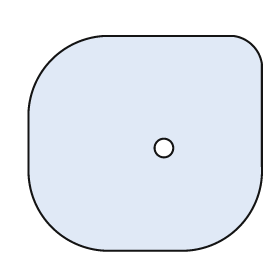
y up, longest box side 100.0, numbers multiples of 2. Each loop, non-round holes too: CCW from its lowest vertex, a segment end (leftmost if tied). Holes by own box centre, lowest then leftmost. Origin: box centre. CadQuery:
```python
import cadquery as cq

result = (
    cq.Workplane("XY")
    .moveTo(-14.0, -46.0)
    .lineTo(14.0, -46.0)
    .threePointArc((40.0, -36.0), (50.0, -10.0))
    .lineTo(50.0, 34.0)
    .threePointArc((46.0, 42.0), (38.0, 46.0))
    .lineTo(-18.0, 46.0)
    .threePointArc((-40.0, 36.0), (-50.0, 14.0))
    .lineTo(-50.0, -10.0)
    .threePointArc((-40.0, -36.0), (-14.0, -46.0))
    .close()
    .moveTo(8.0, -2.0)
    .circle(4.0)
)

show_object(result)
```